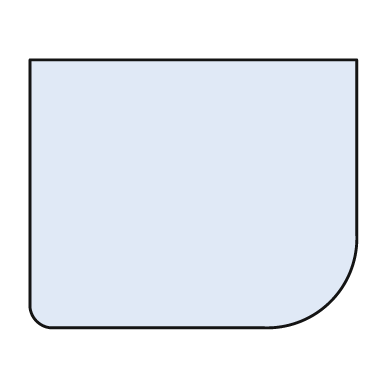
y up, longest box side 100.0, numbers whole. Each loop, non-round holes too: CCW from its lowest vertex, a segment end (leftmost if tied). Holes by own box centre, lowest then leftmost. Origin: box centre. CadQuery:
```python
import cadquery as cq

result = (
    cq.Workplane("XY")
    .moveTo(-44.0, -41.0)
    .lineTo(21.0, -41.0)
    .threePointArc((42.0, -33.0), (50.0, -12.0))
    .lineTo(50.0, 41.0)
    .lineTo(-50.0, 41.0)
    .lineTo(-50.0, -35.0)
    .threePointArc((-48.0, -39.0), (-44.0, -41.0))
    .close()
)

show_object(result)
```